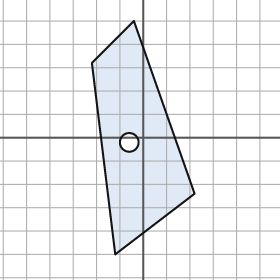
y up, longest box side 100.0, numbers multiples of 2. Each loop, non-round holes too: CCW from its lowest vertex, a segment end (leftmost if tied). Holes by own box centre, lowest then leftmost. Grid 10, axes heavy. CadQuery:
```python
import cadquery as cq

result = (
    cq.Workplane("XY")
    .moveTo(-12.0, -50.0)
    .lineTo(22.0, -24.0)
    .lineTo(-4.0, 50.0)
    .lineTo(-22.0, 32.0)
    .close()
    .moveTo(-6.0, -2.0)
    .circle(4.0)
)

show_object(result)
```